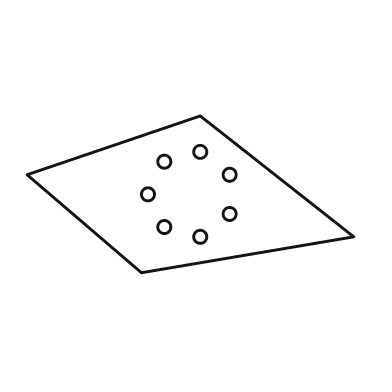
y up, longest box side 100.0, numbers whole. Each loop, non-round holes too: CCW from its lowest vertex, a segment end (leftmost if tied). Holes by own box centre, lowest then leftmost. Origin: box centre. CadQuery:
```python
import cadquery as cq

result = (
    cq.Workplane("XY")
    .moveTo(-15.0, -24.0)
    .lineTo(50.0, -13.0)
    .lineTo(3.0, 24.0)
    .lineTo(-50.0, 6.0)
    .close()
    .moveTo(3.0, -13.0)
    .circle(2.0)
    .moveTo(-8.0, -10.0)
    .circle(2.0)
    .moveTo(12.0, -6.0)
    .circle(2.0)
    .moveTo(-13.0, 0.0)
    .circle(2.0)
    .moveTo(12.0, 6.0)
    .circle(2.0)
    .moveTo(-8.0, 10.0)
    .circle(2.0)
    .moveTo(3.0, 13.0)
    .circle(2.0)
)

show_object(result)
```